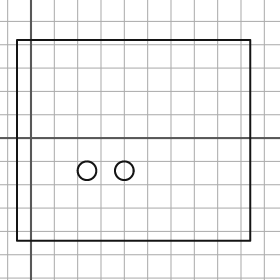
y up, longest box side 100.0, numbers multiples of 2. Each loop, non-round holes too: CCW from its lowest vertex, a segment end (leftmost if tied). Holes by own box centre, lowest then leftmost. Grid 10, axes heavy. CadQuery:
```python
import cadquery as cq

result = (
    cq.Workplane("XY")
    .moveTo(-6.0, -44.0)
    .lineTo(94.0, -44.0)
    .lineTo(94.0, 42.0)
    .lineTo(-6.0, 42.0)
    .close()
    .moveTo(24.0, -14.0)
    .circle(4.0)
    .moveTo(40.0, -14.0)
    .circle(4.0)
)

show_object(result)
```